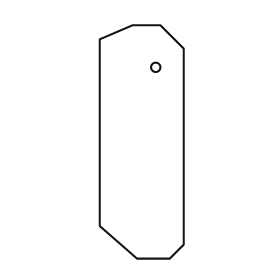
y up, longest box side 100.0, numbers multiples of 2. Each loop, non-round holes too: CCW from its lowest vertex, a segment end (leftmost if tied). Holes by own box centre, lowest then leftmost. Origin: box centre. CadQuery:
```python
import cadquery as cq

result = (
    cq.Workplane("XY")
    .moveTo(-2.0, -50.0)
    .lineTo(12.0, -50.0)
    .lineTo(18.0, -44.0)
    .lineTo(18.0, 40.0)
    .lineTo(8.0, 50.0)
    .lineTo(-4.0, 50.0)
    .lineTo(-18.0, 44.0)
    .lineTo(-18.0, -36.0)
    .close()
    .moveTo(6.0, 32.0)
    .circle(2.0)
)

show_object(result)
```